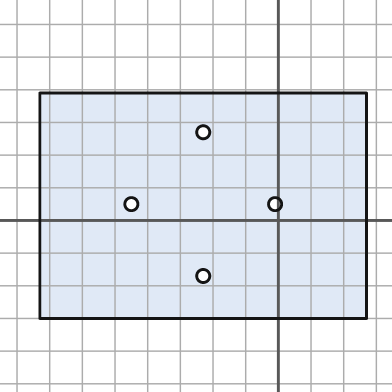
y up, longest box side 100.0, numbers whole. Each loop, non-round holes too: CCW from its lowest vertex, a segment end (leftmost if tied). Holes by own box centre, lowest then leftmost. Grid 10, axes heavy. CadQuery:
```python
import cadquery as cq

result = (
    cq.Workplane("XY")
    .moveTo(-73.0, -30.0)
    .lineTo(27.0, -30.0)
    .lineTo(27.0, 39.0)
    .lineTo(-73.0, 39.0)
    .close()
    .moveTo(-23.0, -17.0)
    .circle(2.0)
    .moveTo(-45.0, 5.0)
    .circle(2.0)
    .moveTo(-1.0, 5.0)
    .circle(2.0)
    .moveTo(-23.0, 27.0)
    .circle(2.0)
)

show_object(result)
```